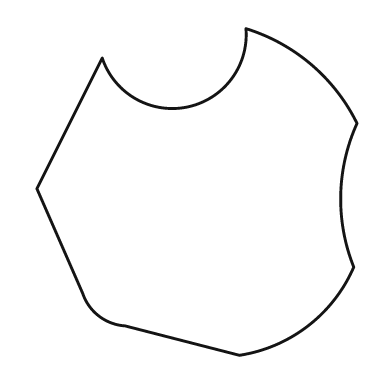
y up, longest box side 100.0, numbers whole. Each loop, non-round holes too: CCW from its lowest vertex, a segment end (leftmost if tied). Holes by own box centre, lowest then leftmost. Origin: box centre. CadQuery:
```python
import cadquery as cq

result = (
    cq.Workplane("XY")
    .moveTo(13.0, -50.0)
    .threePointArc((34.0, -41.0), (48.0, -23.0))
    .threePointArc((44.0, -1.0), (49.0, 21.0))
    .threePointArc((35.0, 39.0), (15.0, 50.0))
    .threePointArc((-3.0, 26.0), (-29.0, 41.0))
    .lineTo(-49.0, 1.0)
    .lineTo(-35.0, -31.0)
    .threePointArc((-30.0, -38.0), (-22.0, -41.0))
    .close()
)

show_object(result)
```